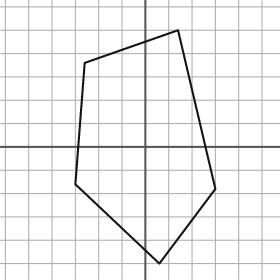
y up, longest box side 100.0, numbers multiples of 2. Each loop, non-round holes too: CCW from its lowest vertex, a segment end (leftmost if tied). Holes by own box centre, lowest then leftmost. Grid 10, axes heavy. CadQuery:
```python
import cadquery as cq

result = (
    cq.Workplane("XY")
    .moveTo(6.0, -50.0)
    .lineTo(30.0, -18.0)
    .lineTo(14.0, 50.0)
    .lineTo(-26.0, 36.0)
    .lineTo(-30.0, -16.0)
    .close()
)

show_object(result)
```